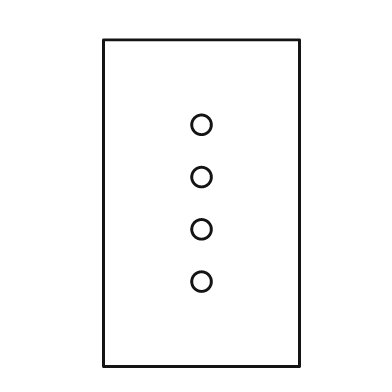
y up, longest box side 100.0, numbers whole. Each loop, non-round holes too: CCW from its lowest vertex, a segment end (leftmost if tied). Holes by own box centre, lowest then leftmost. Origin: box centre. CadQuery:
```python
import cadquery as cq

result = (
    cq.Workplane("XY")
    .moveTo(-30.0, -50.0)
    .lineTo(30.0, -50.0)
    .lineTo(30.0, 50.0)
    .lineTo(-30.0, 50.0)
    .close()
    .moveTo(0.0, -24.0)
    .circle(3.0)
    .moveTo(0.0, -8.0)
    .circle(3.0)
    .moveTo(0.0, 8.0)
    .circle(3.0)
    .moveTo(0.0, 24.0)
    .circle(3.0)
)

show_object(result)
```